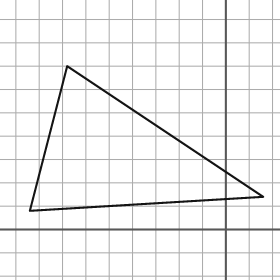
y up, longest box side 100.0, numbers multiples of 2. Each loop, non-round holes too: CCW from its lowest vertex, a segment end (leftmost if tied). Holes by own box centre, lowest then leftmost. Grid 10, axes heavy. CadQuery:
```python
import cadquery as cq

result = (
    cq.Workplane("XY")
    .moveTo(-84.0, 8.0)
    .lineTo(16.0, 14.0)
    .lineTo(-68.0, 70.0)
    .close()
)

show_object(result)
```